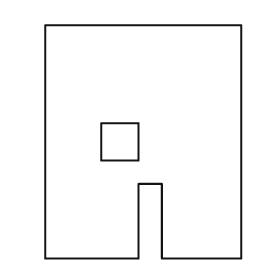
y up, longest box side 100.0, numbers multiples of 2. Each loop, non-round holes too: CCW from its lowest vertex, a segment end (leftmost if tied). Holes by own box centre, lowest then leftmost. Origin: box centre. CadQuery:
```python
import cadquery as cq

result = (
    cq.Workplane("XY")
    .moveTo(-42.0, -50.0)
    .lineTo(-2.0, -50.0)
    .lineTo(-2.0, -18.0)
    .lineTo(8.0, -18.0)
    .lineTo(8.0, -50.0)
    .lineTo(42.0, -50.0)
    .lineTo(42.0, 50.0)
    .lineTo(-42.0, 50.0)
    .close()
    .moveTo(-18.0, -8.0)
    .lineTo(-2.0, -8.0)
    .lineTo(-2.0, 8.0)
    .lineTo(-18.0, 8.0)
    .close()
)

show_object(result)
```